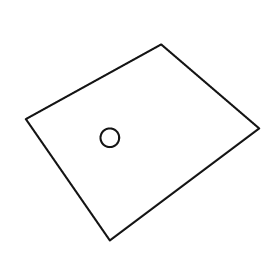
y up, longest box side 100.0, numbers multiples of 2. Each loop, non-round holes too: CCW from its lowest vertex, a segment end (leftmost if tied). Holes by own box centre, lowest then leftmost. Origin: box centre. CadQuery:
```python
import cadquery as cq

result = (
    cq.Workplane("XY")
    .moveTo(-14.0, -42.0)
    .lineTo(50.0, 6.0)
    .lineTo(8.0, 42.0)
    .lineTo(-50.0, 10.0)
    .close()
    .moveTo(-14.0, 2.0)
    .circle(4.0)
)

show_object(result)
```